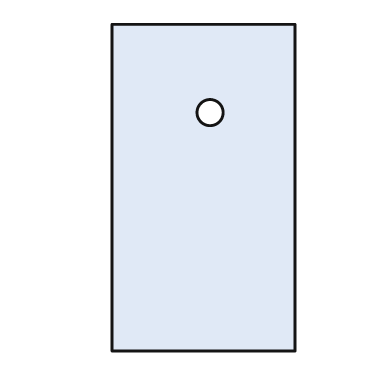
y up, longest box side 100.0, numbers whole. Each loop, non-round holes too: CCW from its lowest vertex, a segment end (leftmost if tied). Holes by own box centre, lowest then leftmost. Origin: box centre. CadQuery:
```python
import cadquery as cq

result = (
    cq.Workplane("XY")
    .moveTo(-28.0, -50.0)
    .lineTo(28.0, -50.0)
    .lineTo(28.0, 50.0)
    .lineTo(-28.0, 50.0)
    .close()
    .moveTo(2.0, 23.0)
    .circle(4.0)
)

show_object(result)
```